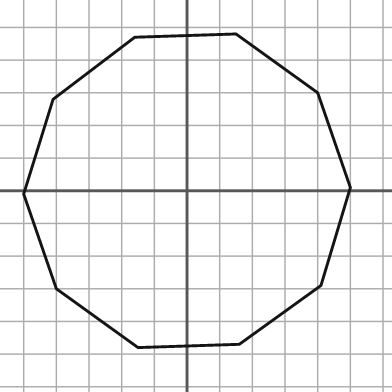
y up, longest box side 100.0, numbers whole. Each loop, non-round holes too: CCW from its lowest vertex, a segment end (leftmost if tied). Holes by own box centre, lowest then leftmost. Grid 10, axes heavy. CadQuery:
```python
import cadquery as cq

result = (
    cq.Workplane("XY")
    .moveTo(-15.0, -48.0)
    .lineTo(16.0, -47.0)
    .lineTo(41.0, -29.0)
    .lineTo(50.0, 1.0)
    .lineTo(40.0, 30.0)
    .lineTo(15.0, 48.0)
    .lineTo(-16.0, 47.0)
    .lineTo(-41.0, 28.0)
    .lineTo(-50.0, -1.0)
    .lineTo(-40.0, -30.0)
    .close()
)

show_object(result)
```